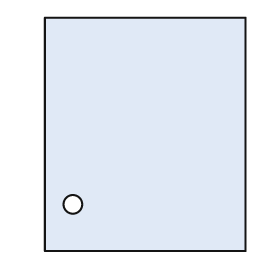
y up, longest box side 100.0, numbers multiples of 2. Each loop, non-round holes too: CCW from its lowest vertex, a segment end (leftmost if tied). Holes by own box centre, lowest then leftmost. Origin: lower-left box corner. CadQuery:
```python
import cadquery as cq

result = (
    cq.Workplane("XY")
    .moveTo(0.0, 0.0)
    .lineTo(86.0, 0.0)
    .lineTo(86.0, 100.0)
    .lineTo(0.0, 100.0)
    .close()
    .moveTo(12.0, 20.0)
    .circle(4.0)
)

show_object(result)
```